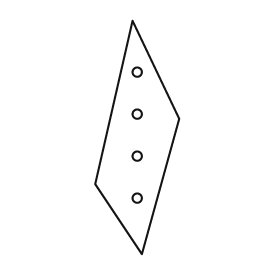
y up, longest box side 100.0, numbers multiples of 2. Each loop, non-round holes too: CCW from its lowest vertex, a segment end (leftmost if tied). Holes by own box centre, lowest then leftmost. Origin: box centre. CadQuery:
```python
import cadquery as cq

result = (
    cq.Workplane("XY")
    .moveTo(2.0, -50.0)
    .lineTo(18.0, 8.0)
    .lineTo(-2.0, 50.0)
    .lineTo(-18.0, -20.0)
    .close()
    .moveTo(0.0, -26.0)
    .circle(2.0)
    .moveTo(0.0, -8.0)
    .circle(2.0)
    .moveTo(0.0, 10.0)
    .circle(2.0)
    .moveTo(0.0, 28.0)
    .circle(2.0)
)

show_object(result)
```